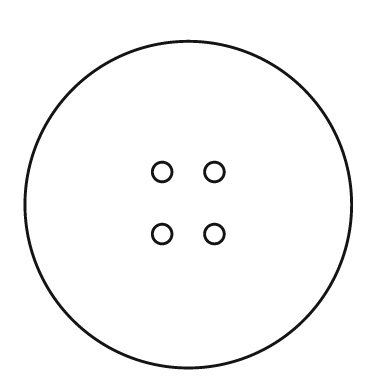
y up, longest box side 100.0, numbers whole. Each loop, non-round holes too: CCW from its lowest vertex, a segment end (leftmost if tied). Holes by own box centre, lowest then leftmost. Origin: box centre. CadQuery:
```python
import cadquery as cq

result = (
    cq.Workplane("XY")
    .moveTo(0.0, 0.0)
    .circle(50.0)
    .moveTo(-8.0, -9.0)
    .circle(3.0)
    .moveTo(8.0, -9.0)
    .circle(3.0)
    .moveTo(-8.0, 10.0)
    .circle(3.0)
    .moveTo(8.0, 10.0)
    .circle(3.0)
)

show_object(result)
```